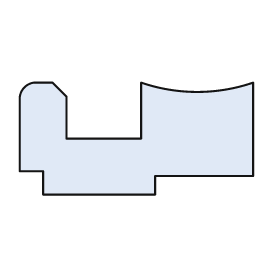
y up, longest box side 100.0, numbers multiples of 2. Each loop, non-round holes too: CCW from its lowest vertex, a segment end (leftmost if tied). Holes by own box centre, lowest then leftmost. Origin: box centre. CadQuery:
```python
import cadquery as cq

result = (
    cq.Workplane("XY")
    .moveTo(-40.0, -24.0)
    .lineTo(8.0, -24.0)
    .lineTo(8.0, -16.0)
    .lineTo(50.0, -16.0)
    .lineTo(50.0, 24.0)
    .threePointArc((26.0, 20.0), (2.0, 24.0))
    .lineTo(2.0, 0.0)
    .lineTo(-30.0, 0.0)
    .lineTo(-30.0, 18.0)
    .lineTo(-36.0, 24.0)
    .lineTo(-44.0, 24.0)
    .threePointArc((-48.0, 22.0), (-50.0, 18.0))
    .lineTo(-50.0, -14.0)
    .lineTo(-40.0, -14.0)
    .close()
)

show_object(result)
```